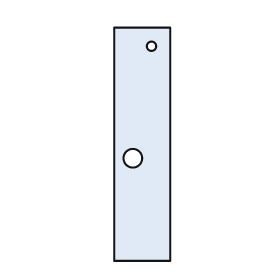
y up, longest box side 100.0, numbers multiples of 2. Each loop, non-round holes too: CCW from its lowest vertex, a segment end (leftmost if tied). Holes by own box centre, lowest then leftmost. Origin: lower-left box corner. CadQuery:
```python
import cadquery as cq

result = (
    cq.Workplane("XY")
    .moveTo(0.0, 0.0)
    .lineTo(24.0, 0.0)
    .lineTo(24.0, 100.0)
    .lineTo(0.0, 100.0)
    .close()
    .moveTo(8.0, 44.0)
    .circle(4.0)
    .moveTo(16.0, 92.0)
    .circle(2.0)
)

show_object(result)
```